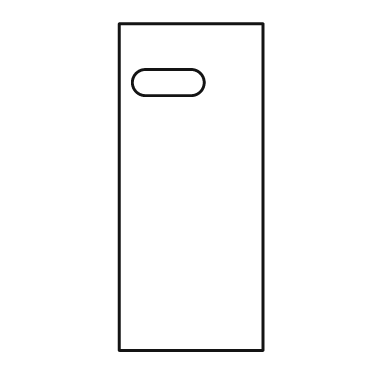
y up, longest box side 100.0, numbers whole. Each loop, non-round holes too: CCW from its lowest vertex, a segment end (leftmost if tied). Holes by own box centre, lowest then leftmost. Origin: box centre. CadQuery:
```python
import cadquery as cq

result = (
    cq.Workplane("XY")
    .moveTo(-22.0, -50.0)
    .lineTo(22.0, -50.0)
    .lineTo(22.0, 50.0)
    .lineTo(-22.0, 50.0)
    .close()
    .moveTo(-14.0, 28.0)
    .lineTo(0.0, 28.0)
    .threePointArc((4.0, 32.0), (0.0, 36.0))
    .lineTo(-14.0, 36.0)
    .threePointArc((-18.0, 32.0), (-14.0, 28.0))
    .close()
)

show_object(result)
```